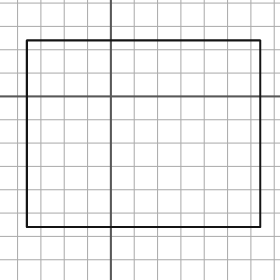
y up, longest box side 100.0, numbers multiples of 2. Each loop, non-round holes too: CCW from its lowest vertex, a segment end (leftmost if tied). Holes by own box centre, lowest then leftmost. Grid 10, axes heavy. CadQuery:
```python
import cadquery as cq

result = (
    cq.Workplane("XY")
    .moveTo(-36.0, -56.0)
    .lineTo(64.0, -56.0)
    .lineTo(64.0, 24.0)
    .lineTo(-36.0, 24.0)
    .close()
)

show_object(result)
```